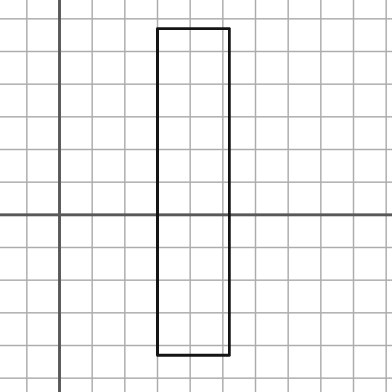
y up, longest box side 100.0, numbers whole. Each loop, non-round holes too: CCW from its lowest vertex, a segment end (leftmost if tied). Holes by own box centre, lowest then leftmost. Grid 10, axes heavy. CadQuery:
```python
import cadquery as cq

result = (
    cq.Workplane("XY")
    .moveTo(30.0, -43.0)
    .lineTo(52.0, -43.0)
    .lineTo(52.0, 57.0)
    .lineTo(30.0, 57.0)
    .close()
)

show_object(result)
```